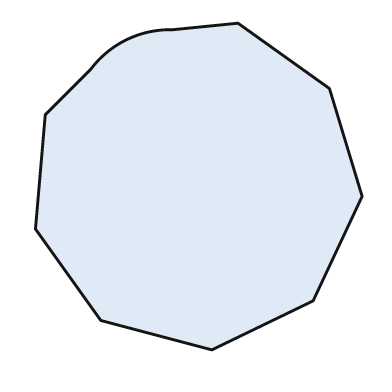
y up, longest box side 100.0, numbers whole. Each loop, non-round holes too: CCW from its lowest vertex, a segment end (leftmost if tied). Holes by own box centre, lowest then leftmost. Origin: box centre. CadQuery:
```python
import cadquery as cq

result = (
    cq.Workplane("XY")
    .moveTo(4.0, -50.0)
    .lineTo(35.0, -35.0)
    .lineTo(50.0, -3.0)
    .lineTo(40.0, 30.0)
    .lineTo(12.0, 50.0)
    .lineTo(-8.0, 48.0)
    .threePointArc((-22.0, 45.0), (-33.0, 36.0))
    .lineTo(-47.0, 22.0)
    .lineTo(-50.0, -13.0)
    .lineTo(-30.0, -41.0)
    .close()
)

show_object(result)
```